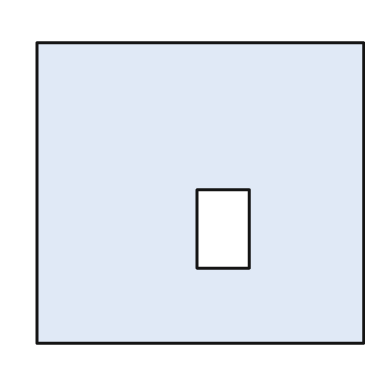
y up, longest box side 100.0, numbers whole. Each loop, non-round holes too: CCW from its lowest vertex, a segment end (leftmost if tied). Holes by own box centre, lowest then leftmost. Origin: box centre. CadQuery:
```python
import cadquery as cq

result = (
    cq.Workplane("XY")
    .moveTo(-50.0, -46.0)
    .lineTo(50.0, -46.0)
    .lineTo(50.0, 46.0)
    .lineTo(-50.0, 46.0)
    .close()
    .moveTo(-1.0, -23.0)
    .lineTo(15.0, -23.0)
    .lineTo(15.0, 1.0)
    .lineTo(-1.0, 1.0)
    .close()
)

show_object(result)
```